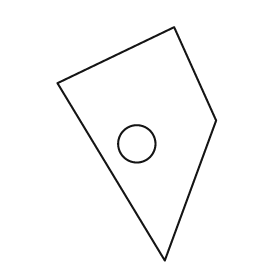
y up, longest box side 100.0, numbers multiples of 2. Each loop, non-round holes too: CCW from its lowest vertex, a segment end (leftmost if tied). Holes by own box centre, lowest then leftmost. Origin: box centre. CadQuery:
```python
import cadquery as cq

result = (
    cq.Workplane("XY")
    .moveTo(12.0, -50.0)
    .lineTo(34.0, 10.0)
    .lineTo(16.0, 50.0)
    .lineTo(-34.0, 26.0)
    .close()
    .moveTo(0.0, 0.0)
    .circle(8.0)
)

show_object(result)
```